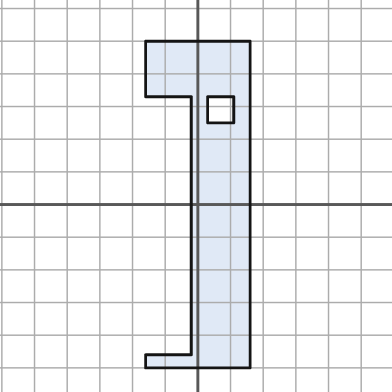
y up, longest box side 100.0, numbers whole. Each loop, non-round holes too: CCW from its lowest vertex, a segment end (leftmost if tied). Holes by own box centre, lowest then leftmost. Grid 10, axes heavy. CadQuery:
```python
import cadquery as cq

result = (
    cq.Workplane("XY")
    .moveTo(-16.0, -50.0)
    .lineTo(16.0, -50.0)
    .lineTo(16.0, 50.0)
    .lineTo(-16.0, 50.0)
    .lineTo(-16.0, 33.0)
    .lineTo(-2.0, 33.0)
    .lineTo(-2.0, -46.0)
    .lineTo(-16.0, -46.0)
    .close()
    .moveTo(3.0, 25.0)
    .lineTo(11.0, 25.0)
    .lineTo(11.0, 33.0)
    .lineTo(3.0, 33.0)
    .close()
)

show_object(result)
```